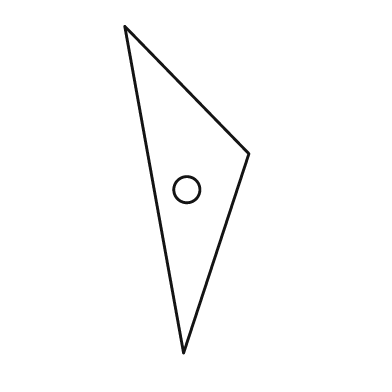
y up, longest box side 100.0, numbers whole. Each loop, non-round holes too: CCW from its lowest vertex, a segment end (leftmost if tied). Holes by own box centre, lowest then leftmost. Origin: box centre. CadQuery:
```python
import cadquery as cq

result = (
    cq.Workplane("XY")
    .moveTo(-1.0, -50.0)
    .lineTo(19.0, 11.0)
    .lineTo(-19.0, 50.0)
    .close()
    .moveTo(0.0, 0.0)
    .circle(4.0)
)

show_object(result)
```